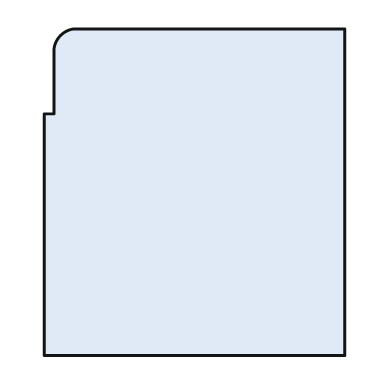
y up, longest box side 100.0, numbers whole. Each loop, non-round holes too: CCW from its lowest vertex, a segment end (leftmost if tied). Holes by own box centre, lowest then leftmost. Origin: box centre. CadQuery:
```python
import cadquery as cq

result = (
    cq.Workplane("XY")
    .moveTo(-46.0, -50.0)
    .lineTo(46.0, -50.0)
    .lineTo(46.0, 50.0)
    .lineTo(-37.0, 50.0)
    .threePointArc((-41.0, 48.0), (-43.0, 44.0))
    .lineTo(-43.0, 24.0)
    .lineTo(-46.0, 24.0)
    .close()
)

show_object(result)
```